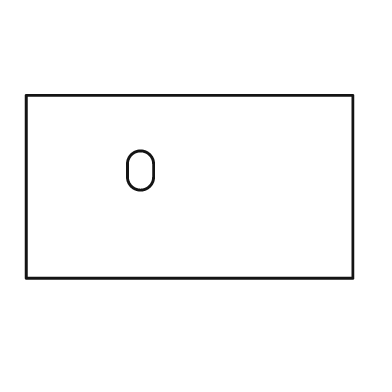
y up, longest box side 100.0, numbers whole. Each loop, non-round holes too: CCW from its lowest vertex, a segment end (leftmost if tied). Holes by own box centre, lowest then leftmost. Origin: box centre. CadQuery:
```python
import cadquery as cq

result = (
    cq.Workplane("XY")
    .moveTo(-50.0, -28.0)
    .lineTo(50.0, -28.0)
    .lineTo(50.0, 28.0)
    .lineTo(-50.0, 28.0)
    .close()
    .moveTo(-19.0, 3.0)
    .threePointArc((-15.0, -1.0), (-11.0, 3.0))
    .lineTo(-11.0, 7.0)
    .threePointArc((-15.0, 11.0), (-19.0, 7.0))
    .close()
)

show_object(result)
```